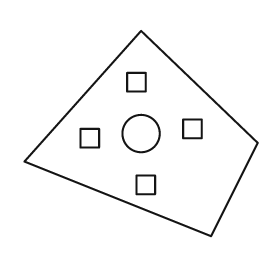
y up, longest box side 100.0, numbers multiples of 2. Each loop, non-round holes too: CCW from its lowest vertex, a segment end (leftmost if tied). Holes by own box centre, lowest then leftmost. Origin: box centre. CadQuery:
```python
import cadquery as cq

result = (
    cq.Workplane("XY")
    .moveTo(30.0, -44.0)
    .lineTo(50.0, -4.0)
    .lineTo(0.0, 44.0)
    .lineTo(-50.0, -12.0)
    .close()
    .moveTo(-2.0, -26.0)
    .lineTo(6.0, -26.0)
    .lineTo(6.0, -18.0)
    .lineTo(-2.0, -18.0)
    .close()
    .moveTo(-26.0, -6.0)
    .lineTo(-18.0, -6.0)
    .lineTo(-18.0, 2.0)
    .lineTo(-26.0, 2.0)
    .close()
    .moveTo(0.0, 0.0)
    .circle(8.0)
    .moveTo(18.0, -2.0)
    .lineTo(26.0, -2.0)
    .lineTo(26.0, 6.0)
    .lineTo(18.0, 6.0)
    .close()
    .moveTo(-6.0, 18.0)
    .lineTo(2.0, 18.0)
    .lineTo(2.0, 26.0)
    .lineTo(-6.0, 26.0)
    .close()
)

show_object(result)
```